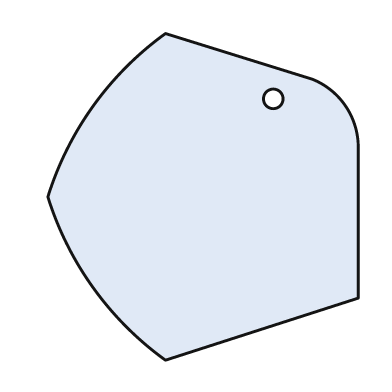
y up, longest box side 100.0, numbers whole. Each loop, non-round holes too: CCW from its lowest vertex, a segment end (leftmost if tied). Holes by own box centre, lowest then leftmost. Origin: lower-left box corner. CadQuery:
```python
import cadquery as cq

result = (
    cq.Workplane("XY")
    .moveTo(36.0, 0.0)
    .lineTo(95.0, 19.0)
    .lineTo(95.0, 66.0)
    .threePointArc((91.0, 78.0), (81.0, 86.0))
    .lineTo(36.0, 100.0)
    .threePointArc((14.0, 78.0), (0.0, 50.0))
    .threePointArc((14.0, 22.0), (36.0, 0.0))
    .close()
    .moveTo(69.0, 80.0)
    .circle(3.0)
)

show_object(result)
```